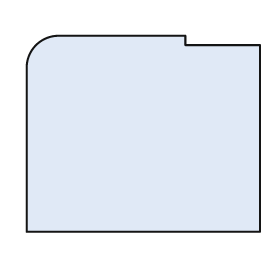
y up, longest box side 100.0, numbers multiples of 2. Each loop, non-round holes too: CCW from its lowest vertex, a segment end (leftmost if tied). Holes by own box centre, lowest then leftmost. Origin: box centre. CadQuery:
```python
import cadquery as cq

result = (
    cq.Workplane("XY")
    .moveTo(-50.0, -42.0)
    .lineTo(50.0, -42.0)
    .lineTo(50.0, 38.0)
    .lineTo(18.0, 38.0)
    .lineTo(18.0, 42.0)
    .lineTo(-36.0, 42.0)
    .threePointArc((-46.0, 38.0), (-50.0, 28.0))
    .close()
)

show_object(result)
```